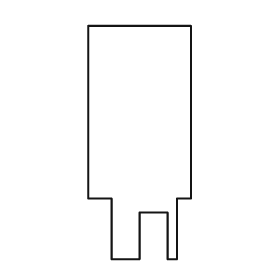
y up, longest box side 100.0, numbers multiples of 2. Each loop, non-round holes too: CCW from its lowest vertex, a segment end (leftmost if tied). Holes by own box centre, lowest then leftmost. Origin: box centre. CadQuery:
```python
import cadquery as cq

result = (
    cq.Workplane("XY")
    .moveTo(-12.0, -50.0)
    .lineTo(0.0, -50.0)
    .lineTo(0.0, -30.0)
    .lineTo(12.0, -30.0)
    .lineTo(12.0, -50.0)
    .lineTo(16.0, -50.0)
    .lineTo(16.0, -24.0)
    .lineTo(22.0, -24.0)
    .lineTo(22.0, 50.0)
    .lineTo(-22.0, 50.0)
    .lineTo(-22.0, -24.0)
    .lineTo(-12.0, -24.0)
    .close()
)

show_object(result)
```